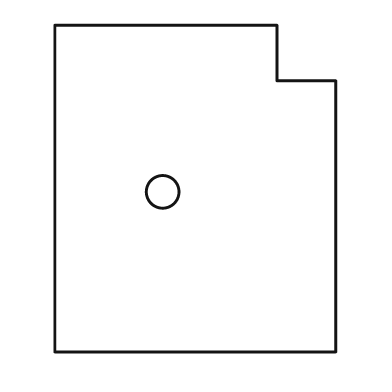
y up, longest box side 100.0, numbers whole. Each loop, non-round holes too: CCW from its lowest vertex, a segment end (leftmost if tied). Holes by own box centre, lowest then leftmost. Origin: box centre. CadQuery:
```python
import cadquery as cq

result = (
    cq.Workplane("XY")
    .moveTo(-43.0, -50.0)
    .lineTo(43.0, -50.0)
    .lineTo(43.0, 33.0)
    .lineTo(25.0, 33.0)
    .lineTo(25.0, 50.0)
    .lineTo(-43.0, 50.0)
    .close()
    .moveTo(-10.0, -1.0)
    .circle(5.0)
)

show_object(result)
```